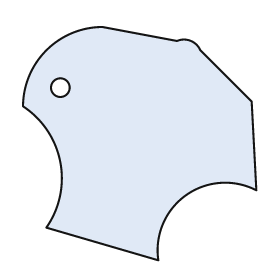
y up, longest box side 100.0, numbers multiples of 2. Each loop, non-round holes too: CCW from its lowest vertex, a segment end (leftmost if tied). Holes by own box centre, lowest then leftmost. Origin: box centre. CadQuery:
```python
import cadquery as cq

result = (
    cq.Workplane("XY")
    .moveTo(8.0, -50.0)
    .threePointArc((20.0, -22.0), (50.0, -20.0))
    .lineTo(48.0, 18.0)
    .lineTo(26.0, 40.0)
    .threePointArc((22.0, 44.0), (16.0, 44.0))
    .lineTo(-16.0, 50.0)
    .threePointArc((-40.0, 40.0), (-50.0, 16.0))
    .threePointArc((-34.0, -8.0), (-40.0, -36.0))
    .close()
    .moveTo(-34.0, 24.0)
    .circle(4.0)
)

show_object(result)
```